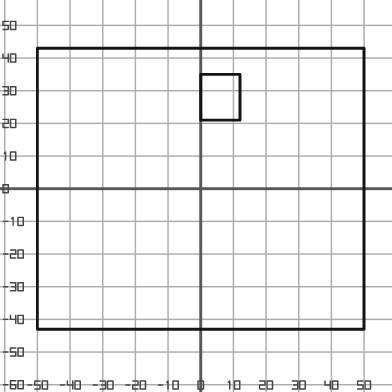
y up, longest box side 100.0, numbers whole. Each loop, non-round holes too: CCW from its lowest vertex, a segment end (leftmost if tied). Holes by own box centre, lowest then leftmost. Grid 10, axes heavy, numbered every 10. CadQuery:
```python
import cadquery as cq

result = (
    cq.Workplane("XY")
    .moveTo(-50.0, -43.0)
    .lineTo(50.0, -43.0)
    .lineTo(50.0, 43.0)
    .lineTo(-50.0, 43.0)
    .close()
    .moveTo(0.0, 21.0)
    .lineTo(12.0, 21.0)
    .lineTo(12.0, 35.0)
    .lineTo(0.0, 35.0)
    .close()
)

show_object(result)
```